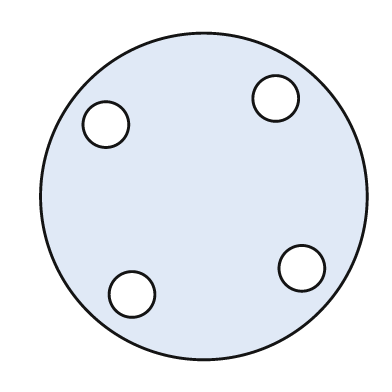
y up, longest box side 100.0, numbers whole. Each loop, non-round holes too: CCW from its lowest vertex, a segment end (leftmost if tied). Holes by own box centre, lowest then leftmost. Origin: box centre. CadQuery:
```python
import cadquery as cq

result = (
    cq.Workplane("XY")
    .moveTo(0.0, 0.0)
    .circle(50.0)
    .moveTo(-22.0, -30.0)
    .circle(7.0)
    .moveTo(30.0, -22.0)
    .circle(7.0)
    .moveTo(-30.0, 22.0)
    .circle(7.0)
    .moveTo(22.0, 30.0)
    .circle(7.0)
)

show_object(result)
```